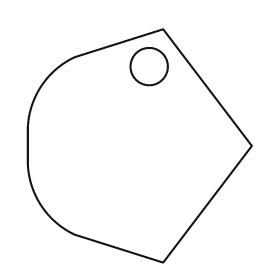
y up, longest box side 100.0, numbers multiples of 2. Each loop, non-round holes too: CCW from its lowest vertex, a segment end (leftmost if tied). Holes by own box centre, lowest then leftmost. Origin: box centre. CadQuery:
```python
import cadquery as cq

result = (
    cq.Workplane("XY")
    .moveTo(10.0, -50.0)
    .lineTo(48.0, 0.0)
    .lineTo(10.0, 50.0)
    .lineTo(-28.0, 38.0)
    .threePointArc((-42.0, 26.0), (-48.0, 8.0))
    .lineTo(-48.0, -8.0)
    .threePointArc((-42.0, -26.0), (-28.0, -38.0))
    .close()
    .moveTo(4.0, 34.0)
    .circle(8.0)
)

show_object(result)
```